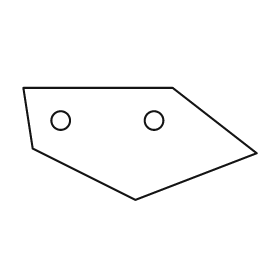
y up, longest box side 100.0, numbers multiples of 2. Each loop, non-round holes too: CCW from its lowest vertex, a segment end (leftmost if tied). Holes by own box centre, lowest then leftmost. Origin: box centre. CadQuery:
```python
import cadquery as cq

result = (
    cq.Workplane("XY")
    .moveTo(-2.0, -24.0)
    .lineTo(50.0, -4.0)
    .lineTo(14.0, 24.0)
    .lineTo(-50.0, 24.0)
    .lineTo(-46.0, -2.0)
    .close()
    .moveTo(-34.0, 10.0)
    .circle(4.0)
    .moveTo(6.0, 10.0)
    .circle(4.0)
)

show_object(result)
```